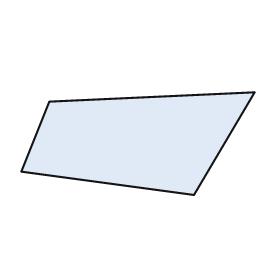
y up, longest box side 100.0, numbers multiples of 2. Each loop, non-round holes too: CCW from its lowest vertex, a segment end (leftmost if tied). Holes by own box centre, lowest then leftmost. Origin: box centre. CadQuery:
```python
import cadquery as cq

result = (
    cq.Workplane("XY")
    .moveTo(24.0, -22.0)
    .lineTo(50.0, 22.0)
    .lineTo(-38.0, 18.0)
    .lineTo(-50.0, -12.0)
    .close()
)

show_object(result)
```